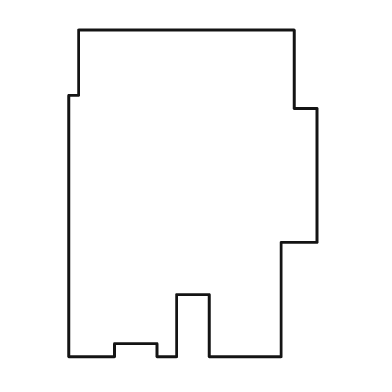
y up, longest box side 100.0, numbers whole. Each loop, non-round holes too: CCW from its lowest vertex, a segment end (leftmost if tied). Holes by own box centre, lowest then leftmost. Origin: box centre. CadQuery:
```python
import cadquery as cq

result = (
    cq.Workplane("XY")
    .moveTo(-38.0, -50.0)
    .lineTo(-24.0, -50.0)
    .lineTo(-24.0, -46.0)
    .lineTo(-11.0, -46.0)
    .lineTo(-11.0, -50.0)
    .lineTo(-5.0, -50.0)
    .lineTo(-5.0, -31.0)
    .lineTo(5.0, -31.0)
    .lineTo(5.0, -50.0)
    .lineTo(27.0, -50.0)
    .lineTo(27.0, -15.0)
    .lineTo(38.0, -15.0)
    .lineTo(38.0, 26.0)
    .lineTo(31.0, 26.0)
    .lineTo(31.0, 50.0)
    .lineTo(-35.0, 50.0)
    .lineTo(-35.0, 30.0)
    .lineTo(-38.0, 30.0)
    .close()
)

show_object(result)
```